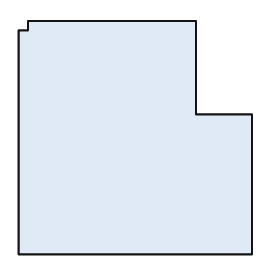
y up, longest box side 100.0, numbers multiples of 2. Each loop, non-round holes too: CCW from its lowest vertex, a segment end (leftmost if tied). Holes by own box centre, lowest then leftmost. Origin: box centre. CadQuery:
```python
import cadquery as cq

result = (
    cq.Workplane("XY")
    .moveTo(-50.0, -50.0)
    .lineTo(50.0, -50.0)
    .lineTo(50.0, 10.0)
    .lineTo(26.0, 10.0)
    .lineTo(26.0, 50.0)
    .lineTo(-46.0, 50.0)
    .lineTo(-46.0, 46.0)
    .lineTo(-50.0, 46.0)
    .close()
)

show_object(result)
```